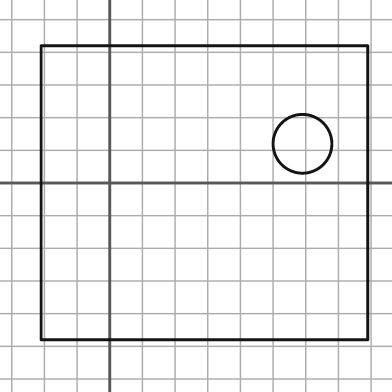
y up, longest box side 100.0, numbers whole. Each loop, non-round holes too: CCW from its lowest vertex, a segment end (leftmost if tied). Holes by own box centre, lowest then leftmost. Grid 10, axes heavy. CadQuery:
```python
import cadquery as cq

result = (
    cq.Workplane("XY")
    .moveTo(-21.0, -48.0)
    .lineTo(79.0, -48.0)
    .lineTo(79.0, 42.0)
    .lineTo(-21.0, 42.0)
    .close()
    .moveTo(59.0, 12.0)
    .circle(9.0)
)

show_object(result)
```